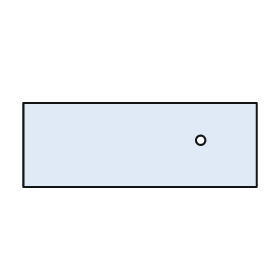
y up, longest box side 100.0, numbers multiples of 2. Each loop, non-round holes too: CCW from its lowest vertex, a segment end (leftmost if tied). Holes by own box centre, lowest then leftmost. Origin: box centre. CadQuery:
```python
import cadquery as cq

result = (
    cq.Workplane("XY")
    .moveTo(-50.0, -18.0)
    .lineTo(50.0, -18.0)
    .lineTo(50.0, 18.0)
    .lineTo(-50.0, 18.0)
    .close()
    .moveTo(26.0, 2.0)
    .circle(2.0)
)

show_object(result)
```